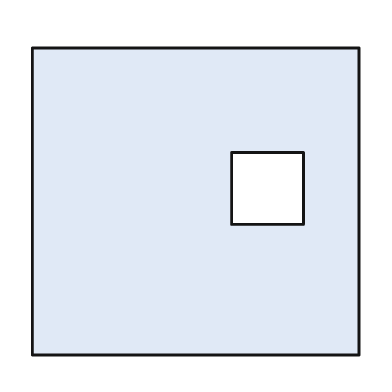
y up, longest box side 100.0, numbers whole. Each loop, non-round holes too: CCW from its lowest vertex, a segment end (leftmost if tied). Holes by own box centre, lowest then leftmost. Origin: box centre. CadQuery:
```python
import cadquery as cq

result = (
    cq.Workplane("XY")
    .moveTo(-50.0, -47.0)
    .lineTo(50.0, -47.0)
    .lineTo(50.0, 47.0)
    .lineTo(-50.0, 47.0)
    .close()
    .moveTo(11.0, -7.0)
    .lineTo(33.0, -7.0)
    .lineTo(33.0, 15.0)
    .lineTo(11.0, 15.0)
    .close()
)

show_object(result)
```